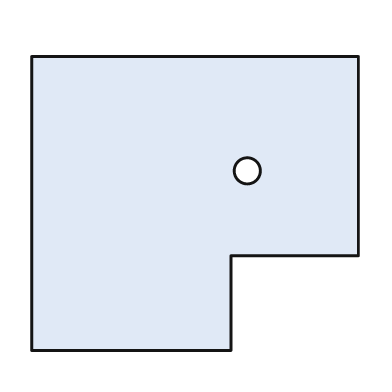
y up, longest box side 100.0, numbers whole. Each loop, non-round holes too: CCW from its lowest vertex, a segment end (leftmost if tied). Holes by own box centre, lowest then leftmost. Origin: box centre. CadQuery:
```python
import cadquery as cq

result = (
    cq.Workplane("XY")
    .moveTo(-50.0, -45.0)
    .lineTo(11.0, -45.0)
    .lineTo(11.0, -16.0)
    .lineTo(50.0, -16.0)
    .lineTo(50.0, 45.0)
    .lineTo(-50.0, 45.0)
    .close()
    .moveTo(16.0, 10.0)
    .circle(4.0)
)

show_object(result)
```